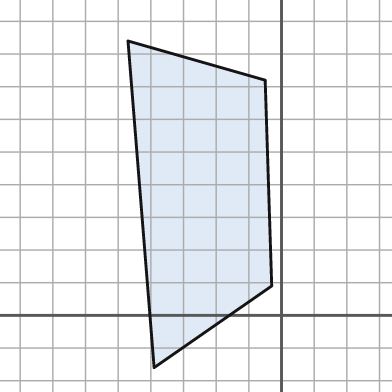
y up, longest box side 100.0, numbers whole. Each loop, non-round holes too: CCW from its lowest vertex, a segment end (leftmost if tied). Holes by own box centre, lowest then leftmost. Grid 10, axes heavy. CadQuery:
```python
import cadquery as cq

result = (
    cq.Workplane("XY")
    .moveTo(-39.0, -16.0)
    .lineTo(-3.0, 9.0)
    .lineTo(-5.0, 72.0)
    .lineTo(-47.0, 84.0)
    .close()
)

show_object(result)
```